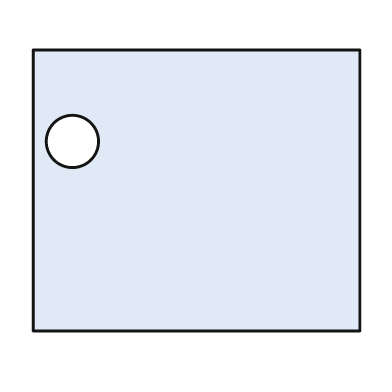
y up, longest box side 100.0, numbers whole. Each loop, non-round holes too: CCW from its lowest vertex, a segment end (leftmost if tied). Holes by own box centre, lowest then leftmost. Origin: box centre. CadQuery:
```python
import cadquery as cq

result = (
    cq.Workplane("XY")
    .moveTo(-50.0, -43.0)
    .lineTo(50.0, -43.0)
    .lineTo(50.0, 43.0)
    .lineTo(-50.0, 43.0)
    .close()
    .moveTo(-38.0, 15.0)
    .circle(8.0)
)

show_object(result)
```